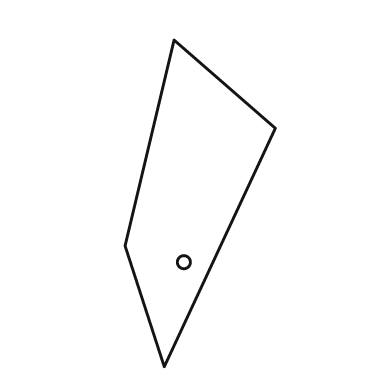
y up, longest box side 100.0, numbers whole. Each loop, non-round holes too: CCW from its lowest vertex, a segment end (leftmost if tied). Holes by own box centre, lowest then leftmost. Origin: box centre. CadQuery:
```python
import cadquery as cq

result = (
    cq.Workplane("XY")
    .moveTo(-11.0, -50.0)
    .lineTo(23.0, 23.0)
    .lineTo(-8.0, 50.0)
    .lineTo(-23.0, -13.0)
    .close()
    .moveTo(-5.0, -18.0)
    .circle(2.0)
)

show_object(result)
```